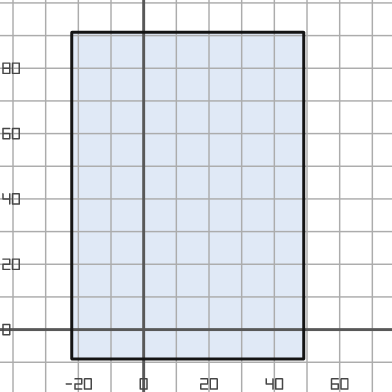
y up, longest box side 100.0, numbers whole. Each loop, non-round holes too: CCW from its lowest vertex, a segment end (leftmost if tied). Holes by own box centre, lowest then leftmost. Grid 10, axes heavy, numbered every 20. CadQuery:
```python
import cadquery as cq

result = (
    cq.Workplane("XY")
    .moveTo(-22.0, -9.0)
    .lineTo(49.0, -9.0)
    .lineTo(49.0, 91.0)
    .lineTo(-22.0, 91.0)
    .close()
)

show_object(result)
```